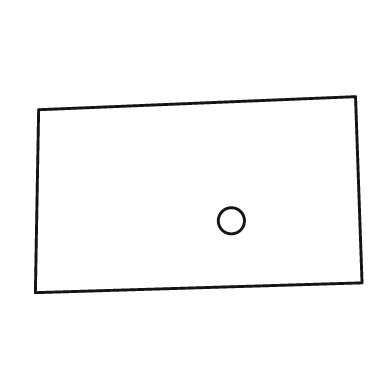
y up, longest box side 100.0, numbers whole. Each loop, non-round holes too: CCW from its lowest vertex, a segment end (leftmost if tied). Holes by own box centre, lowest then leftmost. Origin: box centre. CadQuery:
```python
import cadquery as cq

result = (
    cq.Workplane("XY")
    .moveTo(-50.0, -30.0)
    .lineTo(50.0, -27.0)
    .lineTo(48.0, 30.0)
    .lineTo(-49.0, 26.0)
    .close()
    .moveTo(10.0, -8.0)
    .circle(4.0)
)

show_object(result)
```